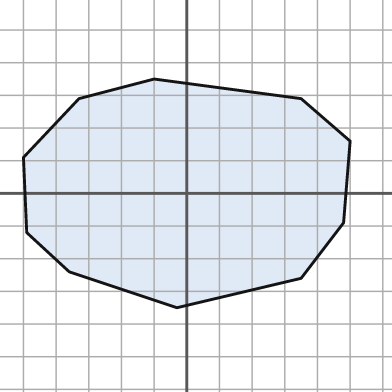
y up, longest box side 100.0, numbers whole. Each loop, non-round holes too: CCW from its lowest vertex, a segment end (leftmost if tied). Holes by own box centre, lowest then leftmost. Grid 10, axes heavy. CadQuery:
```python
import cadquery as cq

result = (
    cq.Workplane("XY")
    .moveTo(-3.0, -35.0)
    .lineTo(35.0, -26.0)
    .lineTo(48.0, -9.0)
    .lineTo(50.0, 16.0)
    .lineTo(35.0, 29.0)
    .lineTo(-10.0, 35.0)
    .lineTo(-33.0, 29.0)
    .lineTo(-50.0, 11.0)
    .lineTo(-49.0, -12.0)
    .lineTo(-36.0, -24.0)
    .close()
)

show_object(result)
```